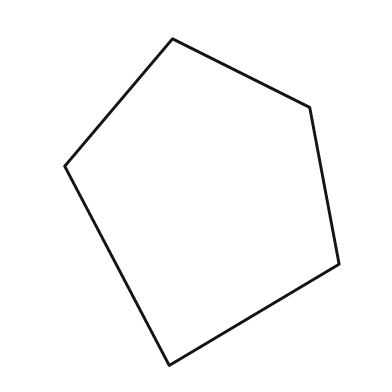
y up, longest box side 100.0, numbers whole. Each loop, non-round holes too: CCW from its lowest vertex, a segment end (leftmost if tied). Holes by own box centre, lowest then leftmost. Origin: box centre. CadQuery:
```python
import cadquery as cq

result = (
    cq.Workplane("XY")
    .moveTo(-10.0, -50.0)
    .lineTo(42.0, -19.0)
    .lineTo(33.0, 29.0)
    .lineTo(-9.0, 50.0)
    .lineTo(-42.0, 11.0)
    .close()
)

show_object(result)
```